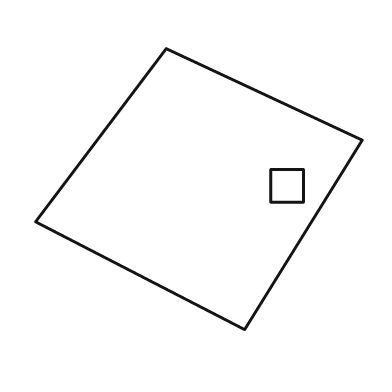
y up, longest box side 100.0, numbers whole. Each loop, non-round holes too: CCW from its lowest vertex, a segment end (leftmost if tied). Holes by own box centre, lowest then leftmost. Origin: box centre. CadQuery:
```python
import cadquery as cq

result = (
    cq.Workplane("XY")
    .moveTo(14.0, -43.0)
    .lineTo(50.0, 15.0)
    .lineTo(-10.0, 43.0)
    .lineTo(-50.0, -10.0)
    .close()
    .moveTo(22.0, -4.0)
    .lineTo(32.0, -4.0)
    .lineTo(32.0, 6.0)
    .lineTo(22.0, 6.0)
    .close()
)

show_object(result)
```